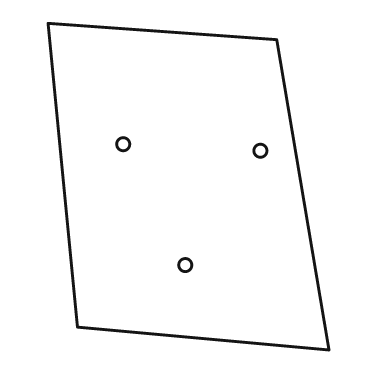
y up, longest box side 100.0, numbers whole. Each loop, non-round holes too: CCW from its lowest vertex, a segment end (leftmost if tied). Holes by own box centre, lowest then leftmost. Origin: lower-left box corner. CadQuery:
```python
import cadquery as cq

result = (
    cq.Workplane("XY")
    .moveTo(86.0, 0.0)
    .lineTo(70.0, 95.0)
    .lineTo(0.0, 100.0)
    .lineTo(9.0, 7.0)
    .close()
    .moveTo(42.0, 26.0)
    .circle(2.0)
    .moveTo(65.0, 61.0)
    .circle(2.0)
    .moveTo(23.0, 63.0)
    .circle(2.0)
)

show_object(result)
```